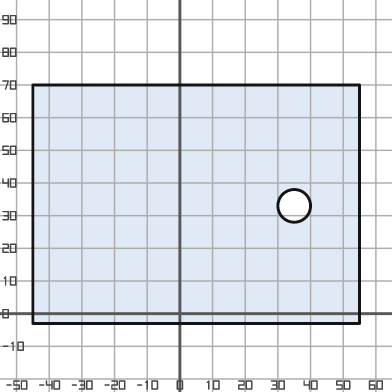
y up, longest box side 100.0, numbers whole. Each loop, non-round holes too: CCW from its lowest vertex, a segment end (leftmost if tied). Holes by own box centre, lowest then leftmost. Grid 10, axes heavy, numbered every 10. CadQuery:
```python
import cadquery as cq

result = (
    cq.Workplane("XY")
    .moveTo(-45.0, -3.0)
    .lineTo(55.0, -3.0)
    .lineTo(55.0, 70.0)
    .lineTo(-45.0, 70.0)
    .close()
    .moveTo(35.0, 33.0)
    .circle(5.0)
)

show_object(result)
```